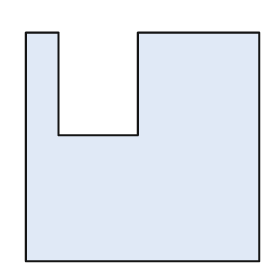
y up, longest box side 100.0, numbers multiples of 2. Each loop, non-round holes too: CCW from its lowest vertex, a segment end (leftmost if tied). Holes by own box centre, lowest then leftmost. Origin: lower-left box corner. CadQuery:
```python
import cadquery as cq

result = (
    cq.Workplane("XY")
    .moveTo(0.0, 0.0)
    .lineTo(100.0, 0.0)
    .lineTo(100.0, 98.0)
    .lineTo(48.0, 98.0)
    .lineTo(48.0, 54.0)
    .lineTo(14.0, 54.0)
    .lineTo(14.0, 98.0)
    .lineTo(0.0, 98.0)
    .close()
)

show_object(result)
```